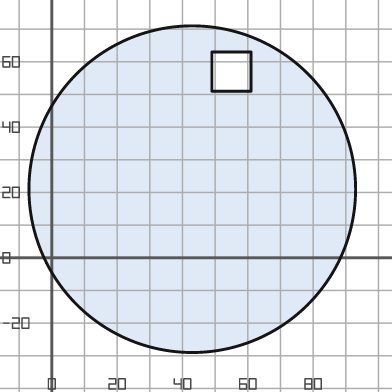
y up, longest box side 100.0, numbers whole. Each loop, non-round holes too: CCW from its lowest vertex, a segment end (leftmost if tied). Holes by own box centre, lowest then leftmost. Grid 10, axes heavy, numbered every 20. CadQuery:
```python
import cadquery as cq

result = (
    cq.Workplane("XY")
    .moveTo(43.0, 21.0)
    .circle(50.0)
    .moveTo(49.0, 51.0)
    .lineTo(61.0, 51.0)
    .lineTo(61.0, 63.0)
    .lineTo(49.0, 63.0)
    .close()
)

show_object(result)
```